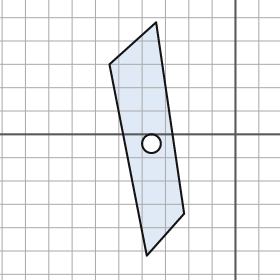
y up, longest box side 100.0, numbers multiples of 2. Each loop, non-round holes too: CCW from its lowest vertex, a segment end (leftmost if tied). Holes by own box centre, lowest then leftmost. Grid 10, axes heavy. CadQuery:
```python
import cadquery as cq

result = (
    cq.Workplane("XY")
    .moveTo(-38.0, -52.0)
    .lineTo(-22.0, -34.0)
    .lineTo(-34.0, 48.0)
    .lineTo(-54.0, 30.0)
    .close()
    .moveTo(-36.0, -4.0)
    .circle(4.0)
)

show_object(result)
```